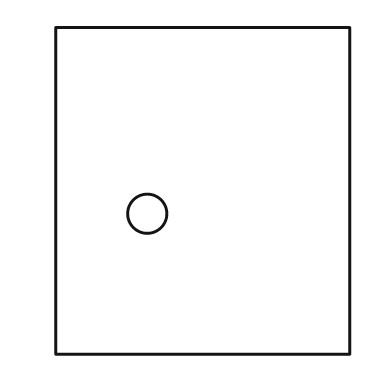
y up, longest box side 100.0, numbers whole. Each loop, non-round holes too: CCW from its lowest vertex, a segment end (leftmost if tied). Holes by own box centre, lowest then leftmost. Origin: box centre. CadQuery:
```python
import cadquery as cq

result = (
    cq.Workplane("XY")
    .moveTo(-45.0, -50.0)
    .lineTo(45.0, -50.0)
    .lineTo(45.0, 50.0)
    .lineTo(-45.0, 50.0)
    .close()
    .moveTo(-17.0, -7.0)
    .circle(6.0)
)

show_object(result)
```